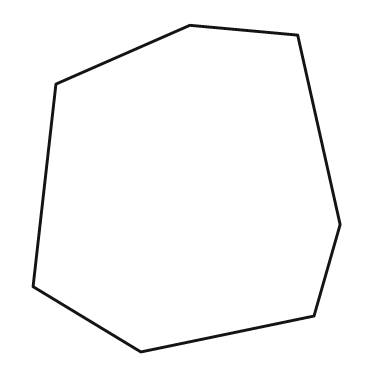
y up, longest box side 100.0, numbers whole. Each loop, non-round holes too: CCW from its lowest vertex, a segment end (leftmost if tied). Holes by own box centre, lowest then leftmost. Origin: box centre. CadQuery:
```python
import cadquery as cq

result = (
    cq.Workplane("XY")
    .moveTo(-14.0, -50.0)
    .lineTo(39.0, -39.0)
    .lineTo(47.0, -11.0)
    .lineTo(34.0, 47.0)
    .lineTo(1.0, 50.0)
    .lineTo(-40.0, 32.0)
    .lineTo(-47.0, -30.0)
    .close()
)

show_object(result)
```